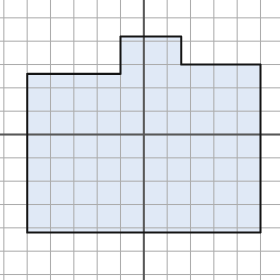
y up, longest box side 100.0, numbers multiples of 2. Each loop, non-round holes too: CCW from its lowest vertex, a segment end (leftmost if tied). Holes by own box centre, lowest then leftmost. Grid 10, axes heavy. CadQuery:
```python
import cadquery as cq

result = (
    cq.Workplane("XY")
    .moveTo(-50.0, -42.0)
    .lineTo(50.0, -42.0)
    .lineTo(50.0, 30.0)
    .lineTo(16.0, 30.0)
    .lineTo(16.0, 42.0)
    .lineTo(-10.0, 42.0)
    .lineTo(-10.0, 26.0)
    .lineTo(-50.0, 26.0)
    .close()
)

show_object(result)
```